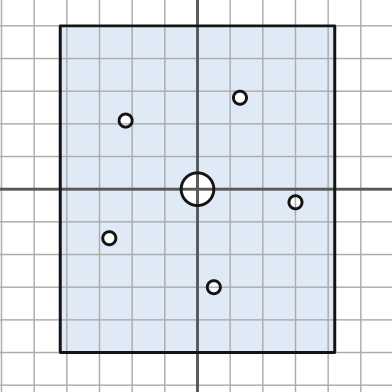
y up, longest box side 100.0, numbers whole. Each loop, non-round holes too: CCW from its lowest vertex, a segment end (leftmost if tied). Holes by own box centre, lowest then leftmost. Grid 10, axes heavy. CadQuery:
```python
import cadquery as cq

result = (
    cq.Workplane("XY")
    .moveTo(-42.0, -50.0)
    .lineTo(42.0, -50.0)
    .lineTo(42.0, 50.0)
    .lineTo(-42.0, 50.0)
    .close()
    .moveTo(5.0, -30.0)
    .circle(2.0)
    .moveTo(-27.0, -15.0)
    .circle(2.0)
    .moveTo(30.0, -4.0)
    .circle(2.0)
    .moveTo(0.0, 0.0)
    .circle(5.0)
    .moveTo(-22.0, 21.0)
    .circle(2.0)
    .moveTo(13.0, 28.0)
    .circle(2.0)
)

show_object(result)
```